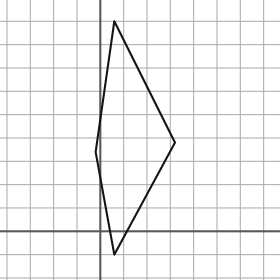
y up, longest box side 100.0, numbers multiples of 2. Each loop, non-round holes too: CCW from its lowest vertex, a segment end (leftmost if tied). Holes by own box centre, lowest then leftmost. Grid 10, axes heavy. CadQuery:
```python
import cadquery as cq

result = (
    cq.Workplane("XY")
    .moveTo(6.0, -10.0)
    .lineTo(32.0, 38.0)
    .lineTo(6.0, 90.0)
    .lineTo(-2.0, 34.0)
    .close()
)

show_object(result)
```